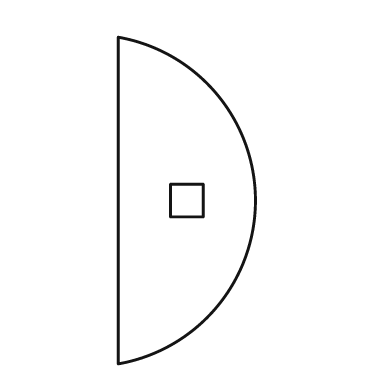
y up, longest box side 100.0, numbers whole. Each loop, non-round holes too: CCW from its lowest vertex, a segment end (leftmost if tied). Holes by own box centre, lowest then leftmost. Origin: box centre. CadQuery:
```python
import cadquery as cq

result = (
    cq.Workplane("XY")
    .moveTo(-21.0, -50.0)
    .threePointArc((21.0, 0.0), (-21.0, 50.0))
    .close()
    .moveTo(-5.0, -5.0)
    .lineTo(5.0, -5.0)
    .lineTo(5.0, 5.0)
    .lineTo(-5.0, 5.0)
    .close()
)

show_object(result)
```